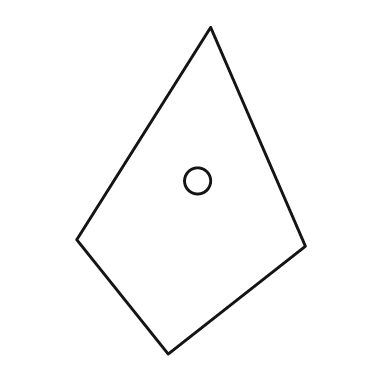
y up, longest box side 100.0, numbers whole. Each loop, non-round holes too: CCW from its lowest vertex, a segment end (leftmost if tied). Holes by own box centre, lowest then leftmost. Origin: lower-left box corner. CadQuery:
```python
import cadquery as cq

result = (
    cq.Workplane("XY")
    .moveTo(28.0, 0.0)
    .lineTo(70.0, 33.0)
    .lineTo(41.0, 100.0)
    .lineTo(0.0, 35.0)
    .close()
    .moveTo(37.0, 53.0)
    .circle(4.0)
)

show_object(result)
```